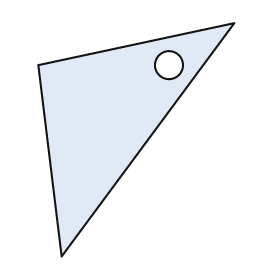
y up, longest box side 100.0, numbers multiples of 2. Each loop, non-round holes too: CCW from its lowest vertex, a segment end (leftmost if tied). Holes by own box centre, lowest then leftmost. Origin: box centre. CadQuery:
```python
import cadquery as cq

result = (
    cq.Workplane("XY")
    .moveTo(-32.0, -50.0)
    .lineTo(42.0, 50.0)
    .lineTo(-42.0, 32.0)
    .close()
    .moveTo(14.0, 32.0)
    .circle(6.0)
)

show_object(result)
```